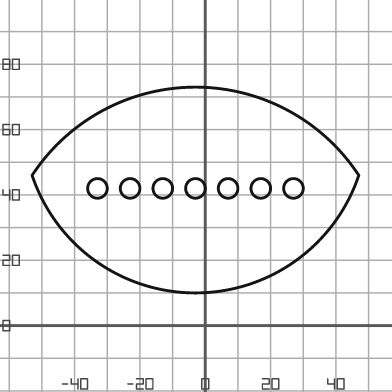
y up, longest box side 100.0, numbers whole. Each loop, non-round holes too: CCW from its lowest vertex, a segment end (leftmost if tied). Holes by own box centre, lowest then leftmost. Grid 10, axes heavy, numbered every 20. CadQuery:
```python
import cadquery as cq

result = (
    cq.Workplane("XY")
    .moveTo(-53.0, 46.0)
    .threePointArc((-3.0, 10.0), (47.0, 46.0))
    .threePointArc((-3.0, 73.0), (-53.0, 46.0))
    .close()
    .moveTo(-33.0, 42.0)
    .circle(3.0)
    .moveTo(-23.0, 42.0)
    .circle(3.0)
    .moveTo(-13.0, 42.0)
    .circle(3.0)
    .moveTo(-3.0, 42.0)
    .circle(3.0)
    .moveTo(7.0, 42.0)
    .circle(3.0)
    .moveTo(17.0, 42.0)
    .circle(3.0)
    .moveTo(27.0, 42.0)
    .circle(3.0)
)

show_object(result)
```